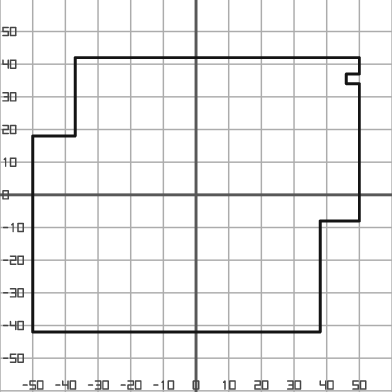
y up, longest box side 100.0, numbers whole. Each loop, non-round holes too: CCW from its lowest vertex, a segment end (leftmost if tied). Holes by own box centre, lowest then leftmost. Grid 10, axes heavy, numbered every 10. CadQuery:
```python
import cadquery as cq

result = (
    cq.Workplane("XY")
    .moveTo(-50.0, -42.0)
    .lineTo(38.0, -42.0)
    .lineTo(38.0, -8.0)
    .lineTo(50.0, -8.0)
    .lineTo(50.0, 34.0)
    .lineTo(46.0, 34.0)
    .lineTo(46.0, 37.0)
    .lineTo(50.0, 37.0)
    .lineTo(50.0, 42.0)
    .lineTo(-37.0, 42.0)
    .lineTo(-37.0, 18.0)
    .lineTo(-50.0, 18.0)
    .close()
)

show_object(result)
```